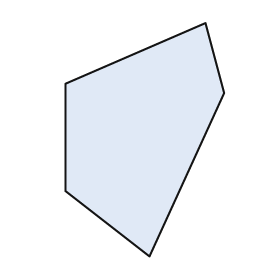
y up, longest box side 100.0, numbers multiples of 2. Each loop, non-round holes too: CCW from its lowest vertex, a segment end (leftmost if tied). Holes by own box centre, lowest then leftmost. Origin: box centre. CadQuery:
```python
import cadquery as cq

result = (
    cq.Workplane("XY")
    .moveTo(2.0, -50.0)
    .lineTo(34.0, 20.0)
    .lineTo(26.0, 50.0)
    .lineTo(-34.0, 24.0)
    .lineTo(-34.0, -22.0)
    .close()
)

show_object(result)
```